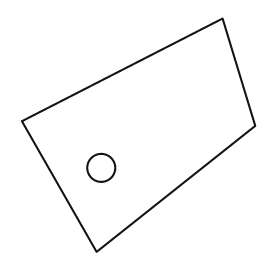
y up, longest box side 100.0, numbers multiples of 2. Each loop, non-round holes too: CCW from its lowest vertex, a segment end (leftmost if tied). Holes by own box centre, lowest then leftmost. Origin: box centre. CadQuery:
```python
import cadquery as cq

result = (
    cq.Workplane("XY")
    .moveTo(-18.0, -50.0)
    .lineTo(50.0, 4.0)
    .lineTo(36.0, 50.0)
    .lineTo(-50.0, 6.0)
    .close()
    .moveTo(-16.0, -14.0)
    .circle(6.0)
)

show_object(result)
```